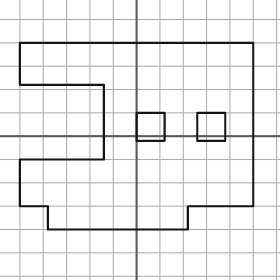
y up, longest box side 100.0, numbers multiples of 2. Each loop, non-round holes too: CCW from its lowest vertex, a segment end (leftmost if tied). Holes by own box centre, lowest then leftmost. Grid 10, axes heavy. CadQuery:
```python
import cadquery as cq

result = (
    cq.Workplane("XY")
    .moveTo(-38.0, -40.0)
    .lineTo(22.0, -40.0)
    .lineTo(22.0, -30.0)
    .lineTo(50.0, -30.0)
    .lineTo(50.0, 40.0)
    .lineTo(-50.0, 40.0)
    .lineTo(-50.0, 22.0)
    .lineTo(-14.0, 22.0)
    .lineTo(-14.0, -10.0)
    .lineTo(-50.0, -10.0)
    .lineTo(-50.0, -30.0)
    .lineTo(-38.0, -30.0)
    .close()
    .moveTo(0.0, -2.0)
    .lineTo(12.0, -2.0)
    .lineTo(12.0, 10.0)
    .lineTo(0.0, 10.0)
    .close()
    .moveTo(26.0, -2.0)
    .lineTo(38.0, -2.0)
    .lineTo(38.0, 10.0)
    .lineTo(26.0, 10.0)
    .close()
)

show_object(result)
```